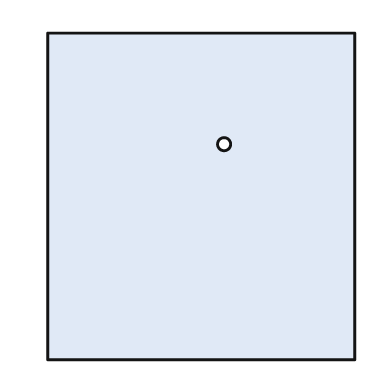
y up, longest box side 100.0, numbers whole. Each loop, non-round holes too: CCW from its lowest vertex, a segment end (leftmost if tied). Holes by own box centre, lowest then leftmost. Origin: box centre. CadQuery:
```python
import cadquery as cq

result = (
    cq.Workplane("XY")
    .moveTo(-47.0, -50.0)
    .lineTo(47.0, -50.0)
    .lineTo(47.0, 50.0)
    .lineTo(-47.0, 50.0)
    .close()
    .moveTo(7.0, 16.0)
    .circle(2.0)
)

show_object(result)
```